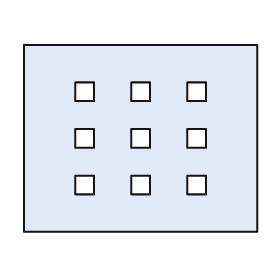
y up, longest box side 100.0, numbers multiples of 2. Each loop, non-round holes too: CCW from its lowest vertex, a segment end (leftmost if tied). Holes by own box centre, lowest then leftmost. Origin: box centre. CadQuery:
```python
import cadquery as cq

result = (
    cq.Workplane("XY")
    .moveTo(-50.0, -40.0)
    .lineTo(50.0, -40.0)
    .lineTo(50.0, 40.0)
    .lineTo(-50.0, 40.0)
    .close()
    .moveTo(-28.0, -24.0)
    .lineTo(-20.0, -24.0)
    .lineTo(-20.0, -16.0)
    .lineTo(-28.0, -16.0)
    .close()
    .moveTo(-4.0, -24.0)
    .lineTo(4.0, -24.0)
    .lineTo(4.0, -16.0)
    .lineTo(-4.0, -16.0)
    .close()
    .moveTo(20.0, -24.0)
    .lineTo(28.0, -24.0)
    .lineTo(28.0, -16.0)
    .lineTo(20.0, -16.0)
    .close()
    .moveTo(-28.0, -4.0)
    .lineTo(-20.0, -4.0)
    .lineTo(-20.0, 4.0)
    .lineTo(-28.0, 4.0)
    .close()
    .moveTo(-4.0, -4.0)
    .lineTo(4.0, -4.0)
    .lineTo(4.0, 4.0)
    .lineTo(-4.0, 4.0)
    .close()
    .moveTo(20.0, -4.0)
    .lineTo(28.0, -4.0)
    .lineTo(28.0, 4.0)
    .lineTo(20.0, 4.0)
    .close()
    .moveTo(-28.0, 16.0)
    .lineTo(-20.0, 16.0)
    .lineTo(-20.0, 24.0)
    .lineTo(-28.0, 24.0)
    .close()
    .moveTo(-4.0, 16.0)
    .lineTo(4.0, 16.0)
    .lineTo(4.0, 24.0)
    .lineTo(-4.0, 24.0)
    .close()
    .moveTo(20.0, 16.0)
    .lineTo(28.0, 16.0)
    .lineTo(28.0, 24.0)
    .lineTo(20.0, 24.0)
    .close()
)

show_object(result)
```